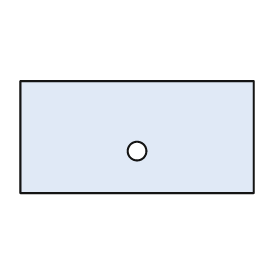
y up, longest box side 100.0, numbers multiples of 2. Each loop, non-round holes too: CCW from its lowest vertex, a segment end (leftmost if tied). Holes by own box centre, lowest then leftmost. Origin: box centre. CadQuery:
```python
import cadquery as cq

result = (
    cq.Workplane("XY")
    .moveTo(-50.0, -24.0)
    .lineTo(50.0, -24.0)
    .lineTo(50.0, 24.0)
    .lineTo(-50.0, 24.0)
    .close()
    .moveTo(0.0, -6.0)
    .circle(4.0)
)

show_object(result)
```